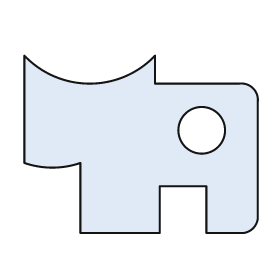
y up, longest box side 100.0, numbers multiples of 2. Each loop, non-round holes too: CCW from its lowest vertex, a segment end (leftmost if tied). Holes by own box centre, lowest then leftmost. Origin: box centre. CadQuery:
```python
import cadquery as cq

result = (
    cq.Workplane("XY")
    .moveTo(-26.0, -38.0)
    .lineTo(8.0, -38.0)
    .lineTo(8.0, -18.0)
    .lineTo(28.0, -18.0)
    .lineTo(28.0, -38.0)
    .lineTo(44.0, -38.0)
    .threePointArc((48.0, -36.0), (50.0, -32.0))
    .lineTo(50.0, 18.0)
    .threePointArc((48.0, 24.0), (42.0, 26.0))
    .lineTo(6.0, 26.0)
    .lineTo(6.0, 38.0)
    .threePointArc((-22.0, 26.0), (-50.0, 38.0))
    .lineTo(-50.0, -8.0)
    .threePointArc((-38.0, -10.0), (-26.0, -8.0))
    .close()
    .moveTo(26.0, 6.0)
    .circle(10.0)
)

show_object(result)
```